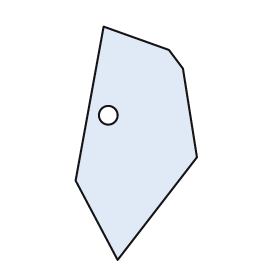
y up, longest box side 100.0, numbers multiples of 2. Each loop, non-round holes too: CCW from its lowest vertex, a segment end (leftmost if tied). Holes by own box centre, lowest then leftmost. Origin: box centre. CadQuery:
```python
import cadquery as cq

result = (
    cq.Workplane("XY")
    .moveTo(-8.0, -50.0)
    .lineTo(26.0, -6.0)
    .lineTo(20.0, 32.0)
    .lineTo(14.0, 40.0)
    .lineTo(-14.0, 50.0)
    .lineTo(-26.0, -16.0)
    .close()
    .moveTo(-12.0, 12.0)
    .circle(4.0)
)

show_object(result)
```